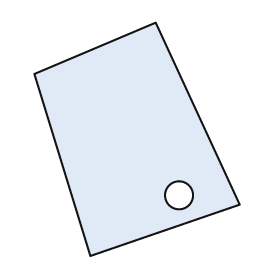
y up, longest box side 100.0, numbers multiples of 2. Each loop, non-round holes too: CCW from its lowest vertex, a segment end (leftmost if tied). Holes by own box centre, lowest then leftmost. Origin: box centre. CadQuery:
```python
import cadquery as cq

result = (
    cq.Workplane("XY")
    .moveTo(-20.0, -50.0)
    .lineTo(44.0, -28.0)
    .lineTo(8.0, 50.0)
    .lineTo(-44.0, 28.0)
    .close()
    .moveTo(18.0, -24.0)
    .circle(6.0)
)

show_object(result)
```